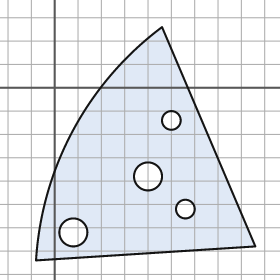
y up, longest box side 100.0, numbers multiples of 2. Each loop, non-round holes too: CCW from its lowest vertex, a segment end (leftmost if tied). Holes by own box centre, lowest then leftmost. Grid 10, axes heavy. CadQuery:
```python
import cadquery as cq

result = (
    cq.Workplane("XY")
    .moveTo(-8.0, -74.0)
    .lineTo(86.0, -68.0)
    .lineTo(46.0, 26.0)
    .threePointArc((8.0, -18.0), (-8.0, -74.0))
    .close()
    .moveTo(8.0, -62.0)
    .circle(6.0)
    .moveTo(56.0, -52.0)
    .circle(4.0)
    .moveTo(40.0, -38.0)
    .circle(6.0)
    .moveTo(50.0, -14.0)
    .circle(4.0)
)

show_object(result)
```